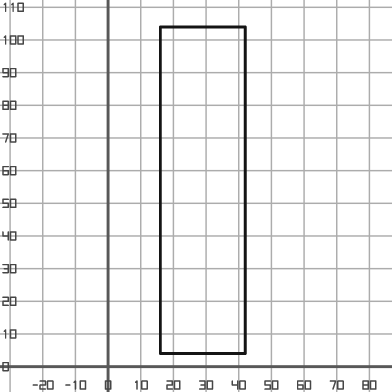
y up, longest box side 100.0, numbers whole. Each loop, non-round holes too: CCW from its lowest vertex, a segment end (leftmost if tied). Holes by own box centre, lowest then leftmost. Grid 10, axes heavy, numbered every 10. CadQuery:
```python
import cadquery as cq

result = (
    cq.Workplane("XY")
    .moveTo(16.0, 4.0)
    .lineTo(42.0, 4.0)
    .lineTo(42.0, 104.0)
    .lineTo(16.0, 104.0)
    .close()
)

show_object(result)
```